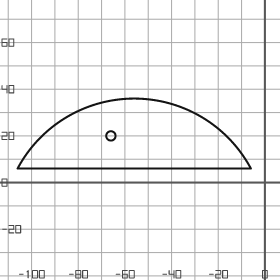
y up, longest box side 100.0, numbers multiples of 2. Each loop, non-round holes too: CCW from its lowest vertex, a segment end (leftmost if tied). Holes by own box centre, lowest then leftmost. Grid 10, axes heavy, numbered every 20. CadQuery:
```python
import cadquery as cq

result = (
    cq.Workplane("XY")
    .moveTo(-106.0, 6.0)
    .lineTo(-6.0, 6.0)
    .threePointArc((-56.0, 36.0), (-106.0, 6.0))
    .close()
    .moveTo(-66.0, 20.0)
    .circle(2.0)
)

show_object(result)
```